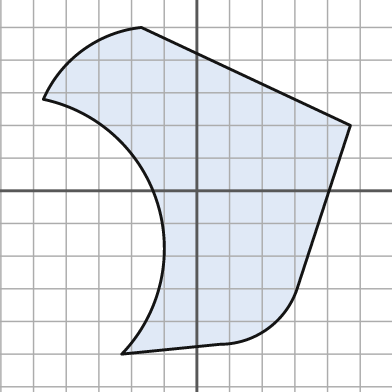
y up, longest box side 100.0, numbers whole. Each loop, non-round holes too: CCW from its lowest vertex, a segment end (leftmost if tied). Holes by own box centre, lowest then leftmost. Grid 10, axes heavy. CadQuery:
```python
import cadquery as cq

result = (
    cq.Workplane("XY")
    .moveTo(-23.0, -50.0)
    .lineTo(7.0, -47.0)
    .threePointArc((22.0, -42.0), (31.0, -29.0))
    .lineTo(47.0, 20.0)
    .lineTo(-17.0, 50.0)
    .threePointArc((-35.0, 43.0), (-47.0, 28.0))
    .threePointArc((-12.0, -4.0), (-23.0, -50.0))
    .close()
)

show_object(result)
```